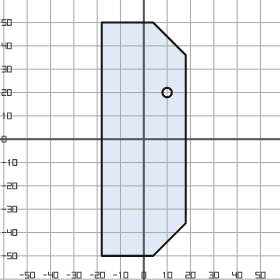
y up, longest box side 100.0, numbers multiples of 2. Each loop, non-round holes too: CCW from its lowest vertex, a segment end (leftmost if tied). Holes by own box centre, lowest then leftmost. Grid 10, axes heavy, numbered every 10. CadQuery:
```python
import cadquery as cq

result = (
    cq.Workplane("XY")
    .moveTo(-18.0, -50.0)
    .lineTo(4.0, -50.0)
    .lineTo(18.0, -36.0)
    .lineTo(18.0, 36.0)
    .lineTo(4.0, 50.0)
    .lineTo(-18.0, 50.0)
    .close()
    .moveTo(10.0, 20.0)
    .circle(2.0)
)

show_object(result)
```